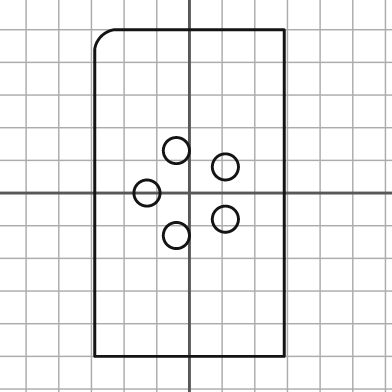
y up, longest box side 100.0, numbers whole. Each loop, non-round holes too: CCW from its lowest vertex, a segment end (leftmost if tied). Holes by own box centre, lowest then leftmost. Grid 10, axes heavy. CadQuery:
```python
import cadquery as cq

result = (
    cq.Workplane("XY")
    .moveTo(-29.0, -50.0)
    .lineTo(29.0, -50.0)
    .lineTo(29.0, 50.0)
    .lineTo(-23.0, 50.0)
    .threePointArc((-27.0, 48.0), (-29.0, 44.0))
    .close()
    .moveTo(-4.0, -13.0)
    .circle(4.0)
    .moveTo(11.0, -8.0)
    .circle(4.0)
    .moveTo(-13.0, 0.0)
    .circle(4.0)
    .moveTo(11.0, 8.0)
    .circle(4.0)
    .moveTo(-4.0, 13.0)
    .circle(4.0)
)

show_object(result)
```